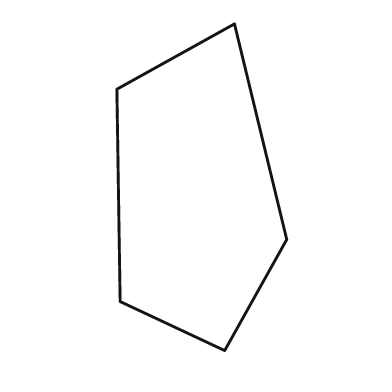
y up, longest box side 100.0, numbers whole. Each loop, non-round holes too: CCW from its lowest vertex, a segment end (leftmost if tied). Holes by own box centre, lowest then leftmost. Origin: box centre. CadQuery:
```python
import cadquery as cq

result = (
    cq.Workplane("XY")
    .moveTo(7.0, -50.0)
    .lineTo(26.0, -16.0)
    .lineTo(10.0, 50.0)
    .lineTo(-26.0, 30.0)
    .lineTo(-25.0, -35.0)
    .close()
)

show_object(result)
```